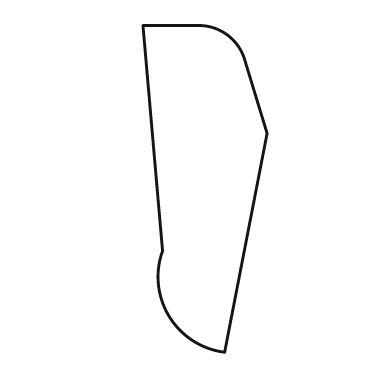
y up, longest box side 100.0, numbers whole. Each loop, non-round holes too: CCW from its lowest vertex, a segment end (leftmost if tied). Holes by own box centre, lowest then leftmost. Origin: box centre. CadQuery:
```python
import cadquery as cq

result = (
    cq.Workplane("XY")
    .moveTo(6.0, -50.0)
    .lineTo(19.0, 17.0)
    .lineTo(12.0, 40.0)
    .threePointArc((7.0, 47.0), (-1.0, 50.0))
    .lineTo(-19.0, 50.0)
    .lineTo(-13.0, -19.0)
    .threePointArc((-11.0, -39.0), (6.0, -50.0))
    .close()
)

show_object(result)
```